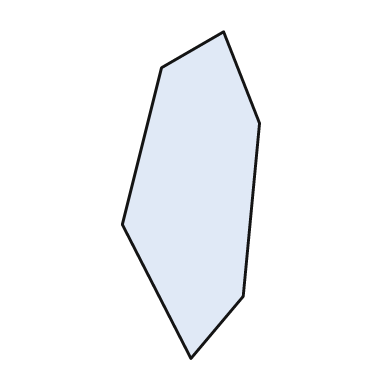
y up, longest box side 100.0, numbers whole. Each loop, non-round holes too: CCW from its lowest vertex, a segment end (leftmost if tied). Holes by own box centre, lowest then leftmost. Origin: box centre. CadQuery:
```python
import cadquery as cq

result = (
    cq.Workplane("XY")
    .moveTo(0.0, -50.0)
    .lineTo(16.0, -31.0)
    .lineTo(21.0, 22.0)
    .lineTo(10.0, 50.0)
    .lineTo(-9.0, 39.0)
    .lineTo(-21.0, -9.0)
    .close()
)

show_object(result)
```